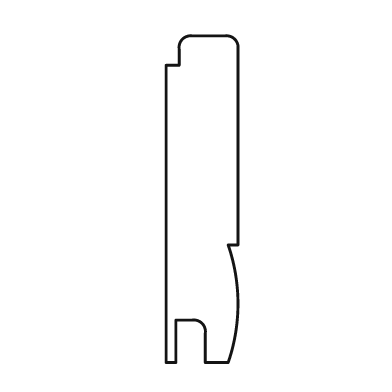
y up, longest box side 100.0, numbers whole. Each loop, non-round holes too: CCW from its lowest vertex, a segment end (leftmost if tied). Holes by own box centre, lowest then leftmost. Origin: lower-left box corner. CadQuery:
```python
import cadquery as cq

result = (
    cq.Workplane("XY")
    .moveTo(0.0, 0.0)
    .lineTo(3.0, 0.0)
    .lineTo(3.0, 13.0)
    .lineTo(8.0, 13.0)
    .threePointArc((11.0, 12.0), (12.0, 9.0))
    .lineTo(12.0, 0.0)
    .lineTo(19.0, 0.0)
    .threePointArc((22.0, 18.0), (19.0, 36.0))
    .lineTo(22.0, 36.0)
    .lineTo(22.0, 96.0)
    .threePointArc((21.0, 99.0), (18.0, 100.0))
    .lineTo(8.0, 100.0)
    .threePointArc((5.0, 99.0), (4.0, 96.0))
    .lineTo(4.0, 91.0)
    .lineTo(0.0, 91.0)
    .close()
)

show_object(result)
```